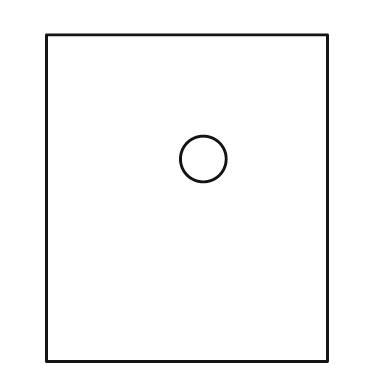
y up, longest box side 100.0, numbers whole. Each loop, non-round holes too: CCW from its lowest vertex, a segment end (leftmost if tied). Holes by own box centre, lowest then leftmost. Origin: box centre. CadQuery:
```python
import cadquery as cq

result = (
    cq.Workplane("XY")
    .moveTo(-43.0, -50.0)
    .lineTo(43.0, -50.0)
    .lineTo(43.0, 50.0)
    .lineTo(-43.0, 50.0)
    .close()
    .moveTo(5.0, 12.0)
    .circle(7.0)
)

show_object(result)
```